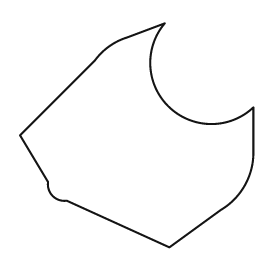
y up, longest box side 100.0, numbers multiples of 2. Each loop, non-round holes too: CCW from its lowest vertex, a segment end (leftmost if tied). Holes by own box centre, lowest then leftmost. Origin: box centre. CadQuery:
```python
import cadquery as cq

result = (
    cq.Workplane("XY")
    .moveTo(14.0, -48.0)
    .lineTo(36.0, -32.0)
    .threePointArc((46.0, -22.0), (50.0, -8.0))
    .lineTo(50.0, 12.0)
    .threePointArc((14.0, 12.0), (12.0, 48.0))
    .lineTo(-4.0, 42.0)
    .threePointArc((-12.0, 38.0), (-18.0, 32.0))
    .lineTo(-50.0, 0.0)
    .lineTo(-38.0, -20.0)
    .threePointArc((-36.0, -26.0), (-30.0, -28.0))
    .close()
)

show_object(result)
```